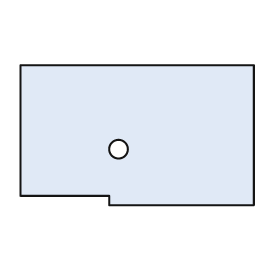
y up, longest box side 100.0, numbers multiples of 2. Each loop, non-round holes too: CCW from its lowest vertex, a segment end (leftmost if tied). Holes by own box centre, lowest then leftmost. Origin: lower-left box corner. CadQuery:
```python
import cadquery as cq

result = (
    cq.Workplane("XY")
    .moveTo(38.0, 0.0)
    .lineTo(100.0, 0.0)
    .lineTo(100.0, 60.0)
    .lineTo(0.0, 60.0)
    .lineTo(0.0, 4.0)
    .lineTo(38.0, 4.0)
    .close()
    .moveTo(42.0, 24.0)
    .circle(4.0)
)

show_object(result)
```